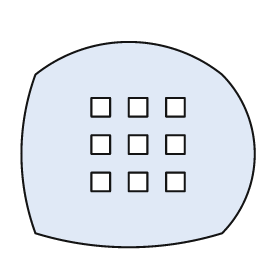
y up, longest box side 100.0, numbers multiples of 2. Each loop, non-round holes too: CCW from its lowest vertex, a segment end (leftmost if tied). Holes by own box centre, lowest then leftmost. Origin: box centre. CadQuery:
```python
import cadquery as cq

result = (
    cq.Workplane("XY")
    .moveTo(-44.0, -38.0)
    .threePointArc((-4.0, -44.0), (36.0, -38.0))
    .threePointArc((50.0, -4.0), (36.0, 30.0))
    .threePointArc((-4.0, 44.0), (-44.0, 30.0))
    .threePointArc((-50.0, -4.0), (-44.0, -38.0))
    .close()
    .moveTo(-20.0, -20.0)
    .lineTo(-12.0, -20.0)
    .lineTo(-12.0, -12.0)
    .lineTo(-20.0, -12.0)
    .close()
    .moveTo(-4.0, -20.0)
    .lineTo(4.0, -20.0)
    .lineTo(4.0, -12.0)
    .lineTo(-4.0, -12.0)
    .close()
    .moveTo(12.0, -20.0)
    .lineTo(20.0, -20.0)
    .lineTo(20.0, -12.0)
    .lineTo(12.0, -12.0)
    .close()
    .moveTo(-20.0, -4.0)
    .lineTo(-12.0, -4.0)
    .lineTo(-12.0, 4.0)
    .lineTo(-20.0, 4.0)
    .close()
    .moveTo(-4.0, -4.0)
    .lineTo(4.0, -4.0)
    .lineTo(4.0, 4.0)
    .lineTo(-4.0, 4.0)
    .close()
    .moveTo(12.0, -4.0)
    .lineTo(20.0, -4.0)
    .lineTo(20.0, 4.0)
    .lineTo(12.0, 4.0)
    .close()
    .moveTo(-20.0, 12.0)
    .lineTo(-12.0, 12.0)
    .lineTo(-12.0, 20.0)
    .lineTo(-20.0, 20.0)
    .close()
    .moveTo(-4.0, 12.0)
    .lineTo(4.0, 12.0)
    .lineTo(4.0, 20.0)
    .lineTo(-4.0, 20.0)
    .close()
    .moveTo(12.0, 12.0)
    .lineTo(20.0, 12.0)
    .lineTo(20.0, 20.0)
    .lineTo(12.0, 20.0)
    .close()
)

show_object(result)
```